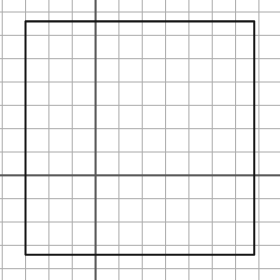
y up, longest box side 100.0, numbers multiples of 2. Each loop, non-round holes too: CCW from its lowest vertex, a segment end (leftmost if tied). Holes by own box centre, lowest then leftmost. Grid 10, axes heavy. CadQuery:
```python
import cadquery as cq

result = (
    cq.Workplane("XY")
    .moveTo(-30.0, -34.0)
    .lineTo(68.0, -34.0)
    .lineTo(68.0, 66.0)
    .lineTo(-30.0, 66.0)
    .close()
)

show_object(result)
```